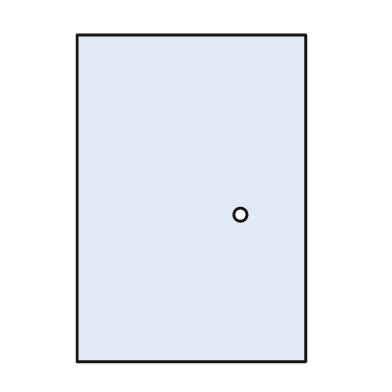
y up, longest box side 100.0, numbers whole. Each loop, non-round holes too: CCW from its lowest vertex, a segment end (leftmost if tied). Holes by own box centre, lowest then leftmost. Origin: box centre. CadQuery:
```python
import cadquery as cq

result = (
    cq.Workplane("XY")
    .moveTo(-35.0, -50.0)
    .lineTo(35.0, -50.0)
    .lineTo(35.0, 50.0)
    .lineTo(-35.0, 50.0)
    .close()
    .moveTo(15.0, -5.0)
    .circle(2.0)
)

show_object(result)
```